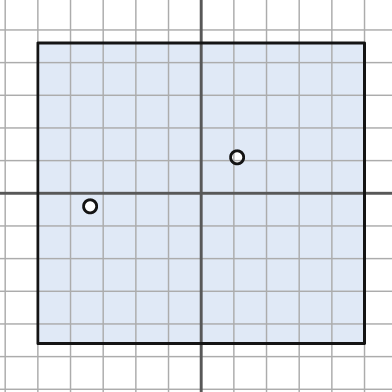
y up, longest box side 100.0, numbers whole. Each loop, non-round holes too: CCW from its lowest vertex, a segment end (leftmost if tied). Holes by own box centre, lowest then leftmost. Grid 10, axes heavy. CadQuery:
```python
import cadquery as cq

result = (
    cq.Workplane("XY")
    .moveTo(-50.0, -46.0)
    .lineTo(50.0, -46.0)
    .lineTo(50.0, 46.0)
    .lineTo(-50.0, 46.0)
    .close()
    .moveTo(-34.0, -4.0)
    .circle(2.0)
    .moveTo(11.0, 11.0)
    .circle(2.0)
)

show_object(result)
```